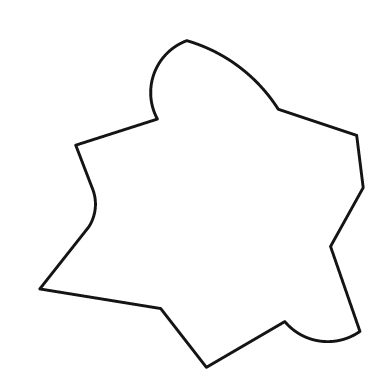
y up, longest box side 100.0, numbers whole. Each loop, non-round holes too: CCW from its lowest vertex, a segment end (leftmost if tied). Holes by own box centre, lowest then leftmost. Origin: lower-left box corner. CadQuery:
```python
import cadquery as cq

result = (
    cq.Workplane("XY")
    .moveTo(51.0, 0.0)
    .lineTo(75.0, 14.0)
    .threePointArc((86.0, 8.0), (98.0, 11.0))
    .lineTo(89.0, 37.0)
    .lineTo(99.0, 55.0)
    .lineTo(97.0, 71.0)
    .lineTo(73.0, 79.0)
    .threePointArc((61.0, 92.0), (45.0, 100.0))
    .threePointArc((35.0, 90.0), (36.0, 76.0))
    .lineTo(11.0, 68.0)
    .lineTo(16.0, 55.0)
    .threePointArc((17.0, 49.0), (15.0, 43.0))
    .lineTo(0.0, 24.0)
    .lineTo(37.0, 18.0)
    .close()
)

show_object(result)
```